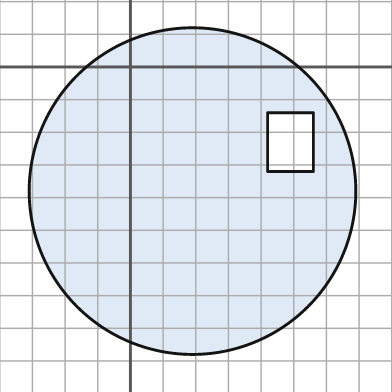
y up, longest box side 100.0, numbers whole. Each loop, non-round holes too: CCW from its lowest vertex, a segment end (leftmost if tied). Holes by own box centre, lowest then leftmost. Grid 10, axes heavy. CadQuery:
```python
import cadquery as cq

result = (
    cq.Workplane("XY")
    .moveTo(19.0, -38.0)
    .circle(50.0)
    .moveTo(42.0, -32.0)
    .lineTo(56.0, -32.0)
    .lineTo(56.0, -14.0)
    .lineTo(42.0, -14.0)
    .close()
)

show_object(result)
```